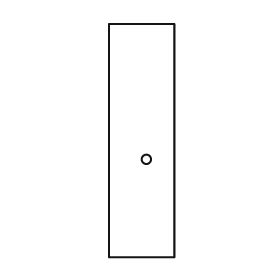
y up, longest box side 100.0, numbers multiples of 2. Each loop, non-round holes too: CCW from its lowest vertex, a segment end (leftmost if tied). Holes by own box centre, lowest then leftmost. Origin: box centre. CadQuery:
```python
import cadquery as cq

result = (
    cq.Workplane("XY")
    .moveTo(-14.0, -50.0)
    .lineTo(14.0, -50.0)
    .lineTo(14.0, 50.0)
    .lineTo(-14.0, 50.0)
    .close()
    .moveTo(2.0, -8.0)
    .circle(2.0)
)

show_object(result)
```